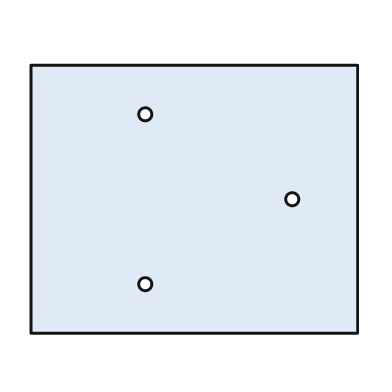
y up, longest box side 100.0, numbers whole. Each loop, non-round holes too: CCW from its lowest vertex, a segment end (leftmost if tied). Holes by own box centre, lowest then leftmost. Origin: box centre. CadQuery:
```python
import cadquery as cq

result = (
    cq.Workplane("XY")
    .moveTo(-50.0, -41.0)
    .lineTo(50.0, -41.0)
    .lineTo(50.0, 41.0)
    .lineTo(-50.0, 41.0)
    .close()
    .moveTo(-15.0, -26.0)
    .circle(2.0)
    .moveTo(30.0, 0.0)
    .circle(2.0)
    .moveTo(-15.0, 26.0)
    .circle(2.0)
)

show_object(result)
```